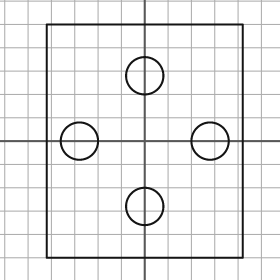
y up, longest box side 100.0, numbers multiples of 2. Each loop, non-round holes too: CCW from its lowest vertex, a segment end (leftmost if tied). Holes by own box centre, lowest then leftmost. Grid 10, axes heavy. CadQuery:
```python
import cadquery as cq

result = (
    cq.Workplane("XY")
    .moveTo(-42.0, -50.0)
    .lineTo(42.0, -50.0)
    .lineTo(42.0, 50.0)
    .lineTo(-42.0, 50.0)
    .close()
    .moveTo(0.0, -28.0)
    .circle(8.0)
    .moveTo(-28.0, 0.0)
    .circle(8.0)
    .moveTo(28.0, 0.0)
    .circle(8.0)
    .moveTo(0.0, 28.0)
    .circle(8.0)
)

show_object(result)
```